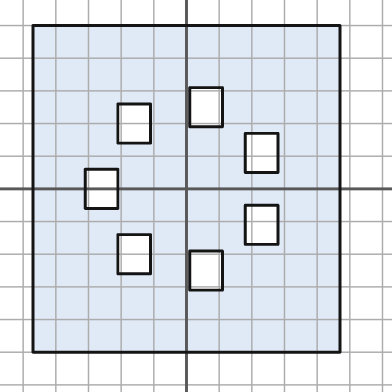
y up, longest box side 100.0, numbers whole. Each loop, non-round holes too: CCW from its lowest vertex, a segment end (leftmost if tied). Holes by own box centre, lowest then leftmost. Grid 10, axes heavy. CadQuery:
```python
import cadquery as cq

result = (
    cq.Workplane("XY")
    .moveTo(-47.0, -50.0)
    .lineTo(47.0, -50.0)
    .lineTo(47.0, 50.0)
    .lineTo(-47.0, 50.0)
    .close()
    .moveTo(1.0, -31.0)
    .lineTo(11.0, -31.0)
    .lineTo(11.0, -19.0)
    .lineTo(1.0, -19.0)
    .close()
    .moveTo(-21.0, -26.0)
    .lineTo(-11.0, -26.0)
    .lineTo(-11.0, -14.0)
    .lineTo(-21.0, -14.0)
    .close()
    .moveTo(18.0, -17.0)
    .lineTo(28.0, -17.0)
    .lineTo(28.0, -5.0)
    .lineTo(18.0, -5.0)
    .close()
    .moveTo(-31.0, -6.0)
    .lineTo(-21.0, -6.0)
    .lineTo(-21.0, 6.0)
    .lineTo(-31.0, 6.0)
    .close()
    .moveTo(18.0, 5.0)
    .lineTo(28.0, 5.0)
    .lineTo(28.0, 17.0)
    .lineTo(18.0, 17.0)
    .close()
    .moveTo(-21.0, 14.0)
    .lineTo(-11.0, 14.0)
    .lineTo(-11.0, 26.0)
    .lineTo(-21.0, 26.0)
    .close()
    .moveTo(1.0, 19.0)
    .lineTo(11.0, 19.0)
    .lineTo(11.0, 31.0)
    .lineTo(1.0, 31.0)
    .close()
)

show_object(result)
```